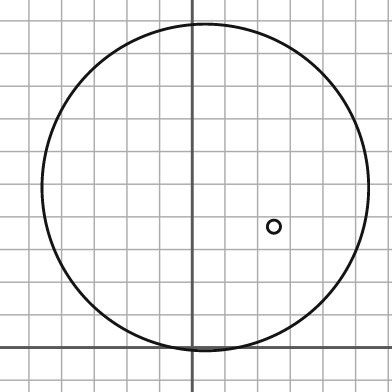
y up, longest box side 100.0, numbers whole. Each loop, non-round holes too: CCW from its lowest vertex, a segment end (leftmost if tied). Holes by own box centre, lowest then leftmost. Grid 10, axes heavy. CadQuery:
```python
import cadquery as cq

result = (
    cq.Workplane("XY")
    .moveTo(4.0, 49.0)
    .circle(50.0)
    .moveTo(25.0, 37.0)
    .circle(2.0)
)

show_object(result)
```